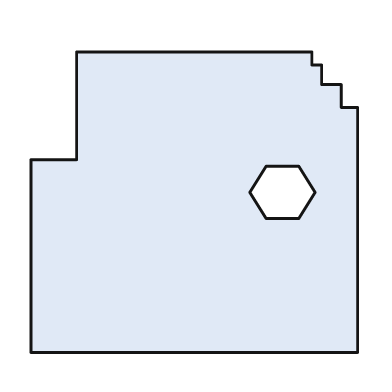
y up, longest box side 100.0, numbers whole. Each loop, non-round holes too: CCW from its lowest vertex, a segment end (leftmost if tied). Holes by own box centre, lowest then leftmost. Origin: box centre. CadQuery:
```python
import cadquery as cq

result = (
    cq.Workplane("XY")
    .moveTo(-50.0, -46.0)
    .lineTo(50.0, -46.0)
    .lineTo(50.0, 29.0)
    .lineTo(45.0, 29.0)
    .lineTo(45.0, 36.0)
    .lineTo(39.0, 36.0)
    .lineTo(39.0, 42.0)
    .lineTo(36.0, 42.0)
    .lineTo(36.0, 46.0)
    .lineTo(-36.0, 46.0)
    .lineTo(-36.0, 13.0)
    .lineTo(-50.0, 13.0)
    .close()
    .moveTo(22.0, -5.0)
    .lineTo(32.0, -5.0)
    .lineTo(37.0, 3.0)
    .lineTo(32.0, 11.0)
    .lineTo(22.0, 11.0)
    .lineTo(17.0, 3.0)
    .close()
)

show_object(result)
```